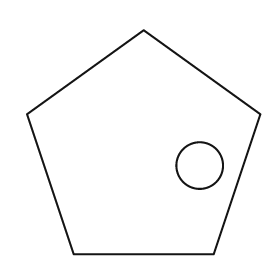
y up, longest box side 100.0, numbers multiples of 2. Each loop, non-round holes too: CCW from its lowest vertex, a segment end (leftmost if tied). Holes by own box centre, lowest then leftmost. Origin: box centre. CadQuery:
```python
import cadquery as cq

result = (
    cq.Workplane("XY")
    .moveTo(-30.0, -48.0)
    .lineTo(30.0, -48.0)
    .lineTo(50.0, 12.0)
    .lineTo(0.0, 48.0)
    .lineTo(-50.0, 12.0)
    .close()
    .moveTo(24.0, -10.0)
    .circle(10.0)
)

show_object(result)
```